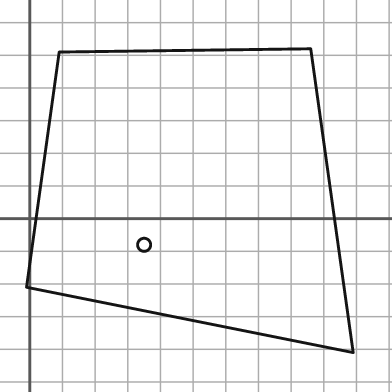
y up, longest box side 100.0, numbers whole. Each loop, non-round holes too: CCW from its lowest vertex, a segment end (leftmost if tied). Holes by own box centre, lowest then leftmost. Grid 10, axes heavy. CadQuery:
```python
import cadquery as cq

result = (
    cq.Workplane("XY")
    .moveTo(99.0, -41.0)
    .lineTo(86.0, 52.0)
    .lineTo(9.0, 51.0)
    .lineTo(-1.0, -21.0)
    .close()
    .moveTo(35.0, -8.0)
    .circle(2.0)
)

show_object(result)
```